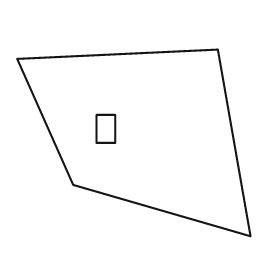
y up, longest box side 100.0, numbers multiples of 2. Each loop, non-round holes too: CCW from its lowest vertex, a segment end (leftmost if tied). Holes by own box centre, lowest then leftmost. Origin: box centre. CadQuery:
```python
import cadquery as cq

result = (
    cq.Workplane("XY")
    .moveTo(50.0, -40.0)
    .lineTo(36.0, 40.0)
    .lineTo(-50.0, 36.0)
    .lineTo(-26.0, -18.0)
    .close()
    .moveTo(-16.0, 0.0)
    .lineTo(-8.0, 0.0)
    .lineTo(-8.0, 12.0)
    .lineTo(-16.0, 12.0)
    .close()
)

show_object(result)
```